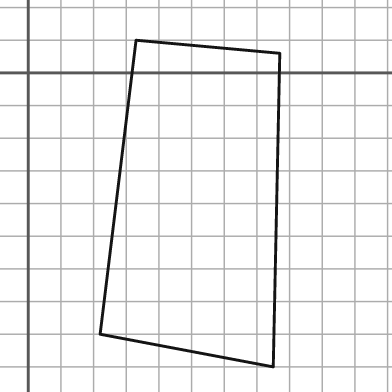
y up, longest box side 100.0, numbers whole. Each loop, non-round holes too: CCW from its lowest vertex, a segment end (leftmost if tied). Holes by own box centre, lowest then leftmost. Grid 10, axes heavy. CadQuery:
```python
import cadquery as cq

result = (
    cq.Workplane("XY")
    .moveTo(75.0, -90.0)
    .lineTo(77.0, 6.0)
    .lineTo(33.0, 10.0)
    .lineTo(22.0, -80.0)
    .close()
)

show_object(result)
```